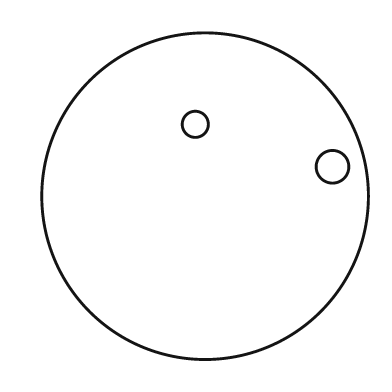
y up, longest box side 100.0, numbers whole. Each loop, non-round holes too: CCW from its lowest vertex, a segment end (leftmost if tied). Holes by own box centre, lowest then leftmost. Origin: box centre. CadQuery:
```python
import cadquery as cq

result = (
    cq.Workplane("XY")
    .moveTo(0.0, 0.0)
    .circle(50.0)
    .moveTo(39.0, 9.0)
    .circle(5.0)
    .moveTo(-3.0, 22.0)
    .circle(4.0)
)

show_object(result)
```